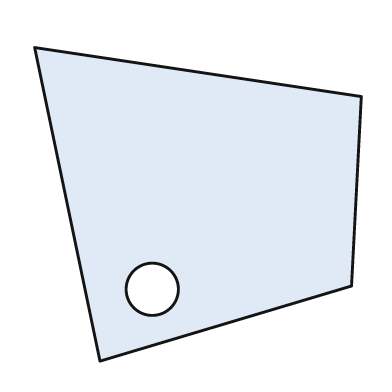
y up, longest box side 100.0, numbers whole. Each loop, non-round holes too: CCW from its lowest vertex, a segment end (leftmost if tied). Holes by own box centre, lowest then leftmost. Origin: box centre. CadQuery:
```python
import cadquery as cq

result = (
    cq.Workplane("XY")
    .moveTo(-30.0, -48.0)
    .lineTo(47.0, -25.0)
    .lineTo(50.0, 33.0)
    .lineTo(-50.0, 48.0)
    .close()
    .moveTo(-14.0, -26.0)
    .circle(8.0)
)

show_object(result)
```